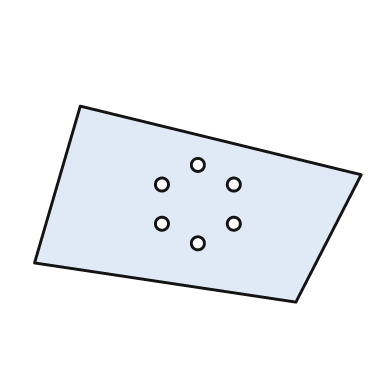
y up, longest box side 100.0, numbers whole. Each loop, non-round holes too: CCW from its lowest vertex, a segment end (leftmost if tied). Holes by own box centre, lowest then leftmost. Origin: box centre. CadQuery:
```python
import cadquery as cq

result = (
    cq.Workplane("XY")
    .moveTo(30.0, -30.0)
    .lineTo(50.0, 9.0)
    .lineTo(-36.0, 30.0)
    .lineTo(-50.0, -18.0)
    .close()
    .moveTo(0.0, -12.0)
    .circle(2.0)
    .moveTo(-11.0, -6.0)
    .circle(2.0)
    .moveTo(11.0, -6.0)
    .circle(2.0)
    .moveTo(-11.0, 6.0)
    .circle(2.0)
    .moveTo(11.0, 6.0)
    .circle(2.0)
    .moveTo(0.0, 12.0)
    .circle(2.0)
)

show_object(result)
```